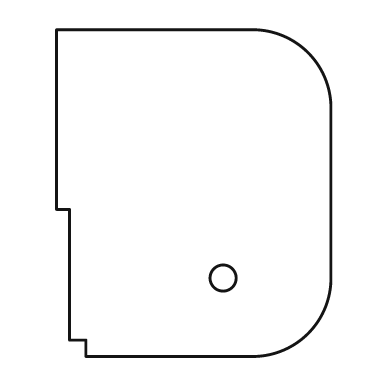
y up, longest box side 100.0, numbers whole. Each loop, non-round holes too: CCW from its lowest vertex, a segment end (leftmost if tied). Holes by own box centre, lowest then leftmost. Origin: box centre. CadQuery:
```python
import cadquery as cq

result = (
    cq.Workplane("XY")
    .moveTo(-33.0, -50.0)
    .lineTo(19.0, -50.0)
    .threePointArc((35.0, -43.0), (42.0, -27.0))
    .lineTo(42.0, 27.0)
    .threePointArc((35.0, 43.0), (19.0, 50.0))
    .lineTo(-42.0, 50.0)
    .lineTo(-42.0, -5.0)
    .lineTo(-38.0, -5.0)
    .lineTo(-38.0, -45.0)
    .lineTo(-33.0, -45.0)
    .close()
    .moveTo(9.0, -26.0)
    .circle(4.0)
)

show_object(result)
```